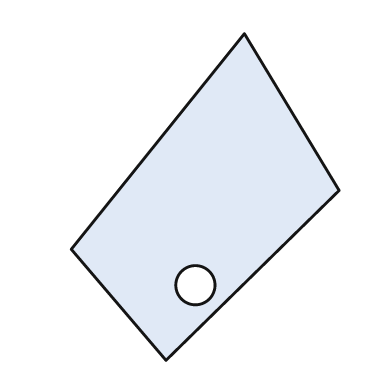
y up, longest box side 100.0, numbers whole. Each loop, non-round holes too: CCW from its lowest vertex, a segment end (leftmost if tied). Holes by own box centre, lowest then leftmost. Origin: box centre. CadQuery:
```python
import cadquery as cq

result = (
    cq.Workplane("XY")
    .moveTo(-12.0, -50.0)
    .lineTo(41.0, 2.0)
    .lineTo(12.0, 50.0)
    .lineTo(-41.0, -16.0)
    .close()
    .moveTo(-3.0, -27.0)
    .circle(6.0)
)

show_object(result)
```